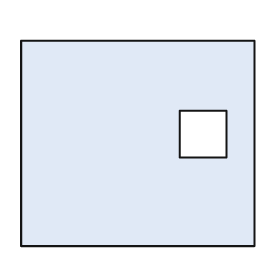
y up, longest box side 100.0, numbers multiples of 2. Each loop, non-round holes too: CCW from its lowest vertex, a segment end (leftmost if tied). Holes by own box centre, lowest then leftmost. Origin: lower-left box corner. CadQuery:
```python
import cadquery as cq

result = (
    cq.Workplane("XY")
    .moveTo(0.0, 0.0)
    .lineTo(100.0, 0.0)
    .lineTo(100.0, 88.0)
    .lineTo(0.0, 88.0)
    .close()
    .moveTo(68.0, 38.0)
    .lineTo(88.0, 38.0)
    .lineTo(88.0, 58.0)
    .lineTo(68.0, 58.0)
    .close()
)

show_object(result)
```